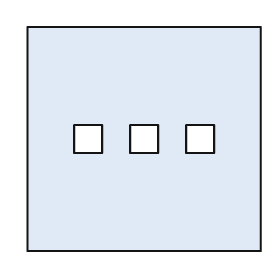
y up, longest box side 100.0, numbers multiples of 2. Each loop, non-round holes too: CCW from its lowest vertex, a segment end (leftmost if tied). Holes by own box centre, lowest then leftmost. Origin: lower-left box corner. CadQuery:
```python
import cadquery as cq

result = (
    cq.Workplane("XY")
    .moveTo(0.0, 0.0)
    .lineTo(100.0, 0.0)
    .lineTo(100.0, 96.0)
    .lineTo(0.0, 96.0)
    .close()
    .moveTo(20.0, 42.0)
    .lineTo(32.0, 42.0)
    .lineTo(32.0, 54.0)
    .lineTo(20.0, 54.0)
    .close()
    .moveTo(44.0, 42.0)
    .lineTo(56.0, 42.0)
    .lineTo(56.0, 54.0)
    .lineTo(44.0, 54.0)
    .close()
    .moveTo(68.0, 42.0)
    .lineTo(80.0, 42.0)
    .lineTo(80.0, 54.0)
    .lineTo(68.0, 54.0)
    .close()
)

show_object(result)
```